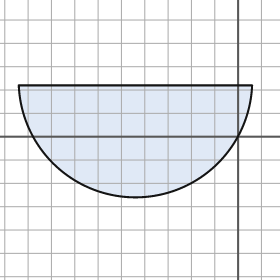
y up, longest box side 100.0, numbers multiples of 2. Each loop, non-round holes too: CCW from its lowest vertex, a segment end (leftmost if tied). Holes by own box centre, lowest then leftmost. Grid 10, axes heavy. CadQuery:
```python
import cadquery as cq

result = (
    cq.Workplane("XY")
    .moveTo(-94.0, 22.0)
    .threePointArc((-44.0, -26.0), (6.0, 22.0))
    .close()
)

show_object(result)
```